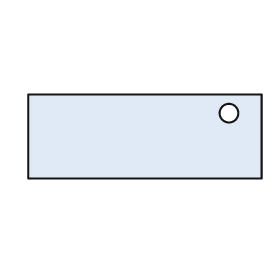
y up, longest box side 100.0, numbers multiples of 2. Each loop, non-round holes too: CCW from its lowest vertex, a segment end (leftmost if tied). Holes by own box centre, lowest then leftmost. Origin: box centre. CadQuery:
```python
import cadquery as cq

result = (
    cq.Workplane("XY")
    .moveTo(-50.0, -18.0)
    .lineTo(50.0, -18.0)
    .lineTo(50.0, 18.0)
    .lineTo(-50.0, 18.0)
    .close()
    .moveTo(36.0, 10.0)
    .circle(4.0)
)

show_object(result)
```